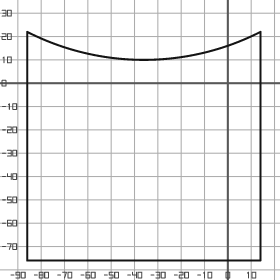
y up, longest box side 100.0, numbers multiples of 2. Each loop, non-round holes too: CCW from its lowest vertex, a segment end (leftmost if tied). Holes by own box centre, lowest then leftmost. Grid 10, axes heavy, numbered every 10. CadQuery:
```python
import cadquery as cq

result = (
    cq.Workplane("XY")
    .moveTo(-86.0, -76.0)
    .lineTo(14.0, -76.0)
    .lineTo(14.0, 22.0)
    .threePointArc((-36.0, 10.0), (-86.0, 22.0))
    .close()
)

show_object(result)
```